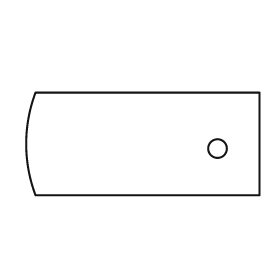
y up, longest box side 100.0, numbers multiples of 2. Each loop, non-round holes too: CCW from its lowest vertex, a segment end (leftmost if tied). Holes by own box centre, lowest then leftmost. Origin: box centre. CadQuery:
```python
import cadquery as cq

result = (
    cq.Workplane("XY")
    .moveTo(-46.0, -22.0)
    .lineTo(50.0, -22.0)
    .lineTo(50.0, 22.0)
    .lineTo(-46.0, 22.0)
    .threePointArc((-50.0, 0.0), (-46.0, -22.0))
    .close()
    .moveTo(32.0, -2.0)
    .circle(4.0)
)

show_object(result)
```